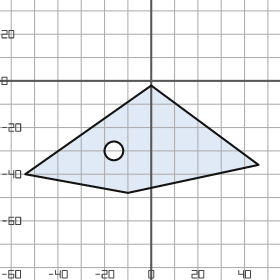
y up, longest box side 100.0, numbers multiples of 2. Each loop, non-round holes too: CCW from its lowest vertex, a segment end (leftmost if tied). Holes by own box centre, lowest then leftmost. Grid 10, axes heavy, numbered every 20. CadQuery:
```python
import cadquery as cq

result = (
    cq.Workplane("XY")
    .moveTo(-10.0, -48.0)
    .lineTo(46.0, -36.0)
    .lineTo(0.0, -2.0)
    .lineTo(-54.0, -40.0)
    .close()
    .moveTo(-16.0, -30.0)
    .circle(4.0)
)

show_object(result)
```